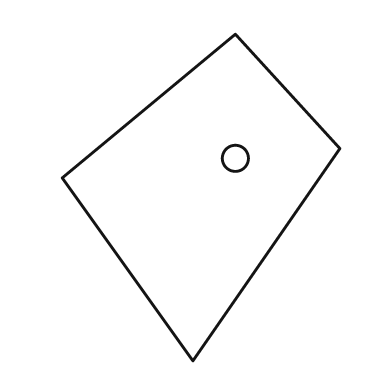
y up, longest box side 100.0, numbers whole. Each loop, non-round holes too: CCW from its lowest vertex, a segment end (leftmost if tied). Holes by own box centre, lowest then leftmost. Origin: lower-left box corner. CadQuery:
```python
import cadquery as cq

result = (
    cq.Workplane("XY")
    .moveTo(40.0, 0.0)
    .lineTo(85.0, 65.0)
    .lineTo(53.0, 100.0)
    .lineTo(0.0, 56.0)
    .close()
    .moveTo(53.0, 62.0)
    .circle(4.0)
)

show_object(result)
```